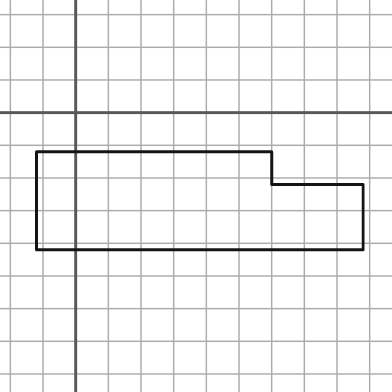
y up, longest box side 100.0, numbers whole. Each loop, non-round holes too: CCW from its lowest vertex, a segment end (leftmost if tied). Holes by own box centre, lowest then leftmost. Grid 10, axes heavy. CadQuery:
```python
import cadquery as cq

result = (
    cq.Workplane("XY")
    .moveTo(-12.0, -42.0)
    .lineTo(88.0, -42.0)
    .lineTo(88.0, -22.0)
    .lineTo(60.0, -22.0)
    .lineTo(60.0, -12.0)
    .lineTo(-12.0, -12.0)
    .close()
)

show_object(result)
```